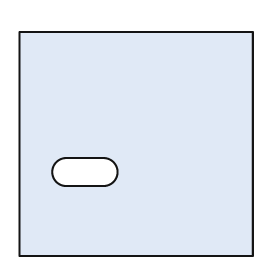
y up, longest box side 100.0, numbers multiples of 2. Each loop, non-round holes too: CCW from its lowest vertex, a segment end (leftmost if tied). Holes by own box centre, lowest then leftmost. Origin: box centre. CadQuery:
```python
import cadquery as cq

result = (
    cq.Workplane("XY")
    .moveTo(-50.0, -48.0)
    .lineTo(50.0, -48.0)
    .lineTo(50.0, 48.0)
    .lineTo(-50.0, 48.0)
    .close()
    .moveTo(-30.0, -18.0)
    .lineTo(-14.0, -18.0)
    .threePointArc((-8.0, -12.0), (-14.0, -6.0))
    .lineTo(-30.0, -6.0)
    .threePointArc((-36.0, -12.0), (-30.0, -18.0))
    .close()
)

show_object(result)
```